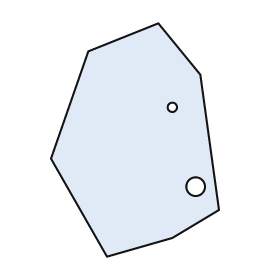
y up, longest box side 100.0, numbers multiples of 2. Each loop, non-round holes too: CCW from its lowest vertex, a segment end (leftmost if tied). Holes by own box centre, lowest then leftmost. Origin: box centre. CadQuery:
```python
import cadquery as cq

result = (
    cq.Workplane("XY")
    .moveTo(-12.0, -50.0)
    .lineTo(16.0, -42.0)
    .lineTo(36.0, -30.0)
    .lineTo(28.0, 28.0)
    .lineTo(10.0, 50.0)
    .lineTo(-20.0, 38.0)
    .lineTo(-36.0, -8.0)
    .close()
    .moveTo(26.0, -20.0)
    .circle(4.0)
    .moveTo(16.0, 14.0)
    .circle(2.0)
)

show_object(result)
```